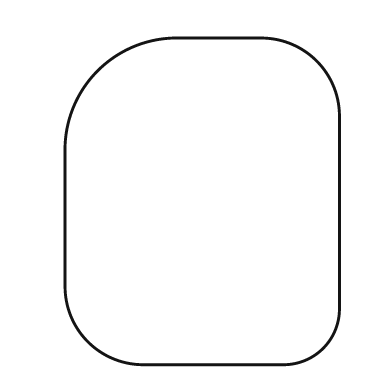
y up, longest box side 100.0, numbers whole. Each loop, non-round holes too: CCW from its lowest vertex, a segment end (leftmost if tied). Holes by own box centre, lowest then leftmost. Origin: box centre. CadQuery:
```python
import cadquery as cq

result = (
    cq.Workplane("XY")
    .moveTo(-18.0, -50.0)
    .lineTo(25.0, -50.0)
    .threePointArc((37.0, -45.0), (42.0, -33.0))
    .lineTo(42.0, 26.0)
    .threePointArc((35.0, 43.0), (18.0, 50.0))
    .lineTo(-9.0, 50.0)
    .threePointArc((-32.0, 40.0), (-42.0, 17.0))
    .lineTo(-42.0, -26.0)
    .threePointArc((-35.0, -43.0), (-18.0, -50.0))
    .close()
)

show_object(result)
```